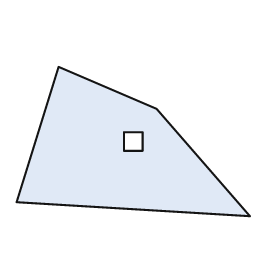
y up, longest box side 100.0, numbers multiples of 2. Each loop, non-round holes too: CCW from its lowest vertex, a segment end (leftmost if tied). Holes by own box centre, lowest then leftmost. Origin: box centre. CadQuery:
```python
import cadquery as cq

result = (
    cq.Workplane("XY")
    .moveTo(50.0, -32.0)
    .lineTo(10.0, 14.0)
    .lineTo(-32.0, 32.0)
    .lineTo(-50.0, -26.0)
    .close()
    .moveTo(-4.0, -4.0)
    .lineTo(4.0, -4.0)
    .lineTo(4.0, 4.0)
    .lineTo(-4.0, 4.0)
    .close()
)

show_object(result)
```